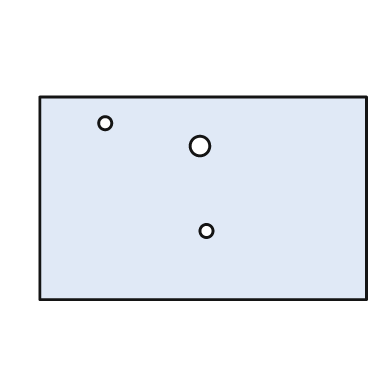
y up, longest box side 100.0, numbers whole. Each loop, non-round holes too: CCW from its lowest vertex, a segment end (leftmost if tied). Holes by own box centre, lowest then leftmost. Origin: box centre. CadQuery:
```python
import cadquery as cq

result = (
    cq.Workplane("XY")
    .moveTo(-50.0, -31.0)
    .lineTo(50.0, -31.0)
    .lineTo(50.0, 31.0)
    .lineTo(-50.0, 31.0)
    .close()
    .moveTo(1.0, -10.0)
    .circle(2.0)
    .moveTo(-1.0, 16.0)
    .circle(3.0)
    .moveTo(-30.0, 23.0)
    .circle(2.0)
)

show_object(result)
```